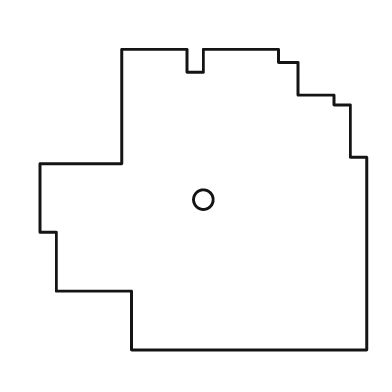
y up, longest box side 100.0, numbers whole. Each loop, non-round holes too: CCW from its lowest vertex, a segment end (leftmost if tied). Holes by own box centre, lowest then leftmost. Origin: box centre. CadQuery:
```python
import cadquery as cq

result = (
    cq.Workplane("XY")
    .moveTo(-22.0, -46.0)
    .lineTo(50.0, -46.0)
    .lineTo(50.0, 13.0)
    .lineTo(45.0, 13.0)
    .lineTo(45.0, 29.0)
    .lineTo(40.0, 29.0)
    .lineTo(40.0, 32.0)
    .lineTo(29.0, 32.0)
    .lineTo(29.0, 42.0)
    .lineTo(23.0, 42.0)
    .lineTo(23.0, 46.0)
    .lineTo(0.0, 46.0)
    .lineTo(0.0, 39.0)
    .lineTo(-5.0, 39.0)
    .lineTo(-5.0, 46.0)
    .lineTo(-25.0, 46.0)
    .lineTo(-25.0, 11.0)
    .lineTo(-50.0, 11.0)
    .lineTo(-50.0, -10.0)
    .lineTo(-45.0, -10.0)
    .lineTo(-45.0, -28.0)
    .lineTo(-22.0, -28.0)
    .close()
    .moveTo(0.0, 0.0)
    .circle(3.0)
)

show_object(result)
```